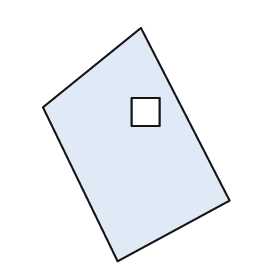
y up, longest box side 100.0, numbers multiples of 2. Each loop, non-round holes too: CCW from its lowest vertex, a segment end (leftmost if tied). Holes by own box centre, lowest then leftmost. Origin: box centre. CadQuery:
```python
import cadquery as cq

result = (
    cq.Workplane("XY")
    .moveTo(-8.0, -50.0)
    .lineTo(40.0, -24.0)
    .lineTo(2.0, 50.0)
    .lineTo(-40.0, 16.0)
    .close()
    .moveTo(-2.0, 8.0)
    .lineTo(10.0, 8.0)
    .lineTo(10.0, 20.0)
    .lineTo(-2.0, 20.0)
    .close()
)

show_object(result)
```